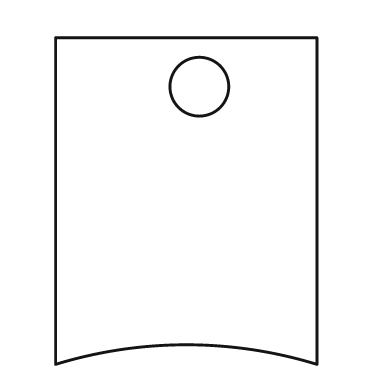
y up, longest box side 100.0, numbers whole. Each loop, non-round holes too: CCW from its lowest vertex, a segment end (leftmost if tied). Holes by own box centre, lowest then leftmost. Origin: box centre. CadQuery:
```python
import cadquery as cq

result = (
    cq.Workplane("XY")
    .moveTo(-40.0, -50.0)
    .threePointArc((0.0, -44.0), (40.0, -50.0))
    .lineTo(40.0, 50.0)
    .lineTo(-40.0, 50.0)
    .close()
    .moveTo(4.0, 35.0)
    .circle(9.0)
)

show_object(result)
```